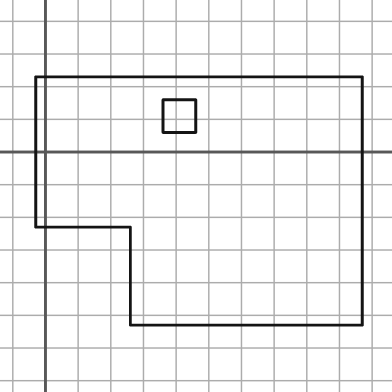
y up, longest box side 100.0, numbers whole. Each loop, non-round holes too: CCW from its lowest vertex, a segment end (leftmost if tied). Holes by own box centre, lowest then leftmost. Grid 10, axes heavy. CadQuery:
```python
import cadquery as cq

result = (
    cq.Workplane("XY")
    .moveTo(26.0, -53.0)
    .lineTo(97.0, -53.0)
    .lineTo(97.0, 23.0)
    .lineTo(-3.0, 23.0)
    .lineTo(-3.0, -23.0)
    .lineTo(26.0, -23.0)
    .close()
    .moveTo(36.0, 6.0)
    .lineTo(46.0, 6.0)
    .lineTo(46.0, 16.0)
    .lineTo(36.0, 16.0)
    .close()
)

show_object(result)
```